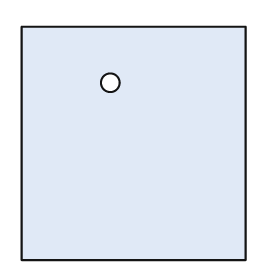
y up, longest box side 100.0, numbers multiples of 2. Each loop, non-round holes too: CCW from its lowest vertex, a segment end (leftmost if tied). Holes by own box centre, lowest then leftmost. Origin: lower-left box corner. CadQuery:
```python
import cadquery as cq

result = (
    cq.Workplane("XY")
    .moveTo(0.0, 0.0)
    .lineTo(96.0, 0.0)
    .lineTo(96.0, 100.0)
    .lineTo(0.0, 100.0)
    .close()
    .moveTo(38.0, 76.0)
    .circle(4.0)
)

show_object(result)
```